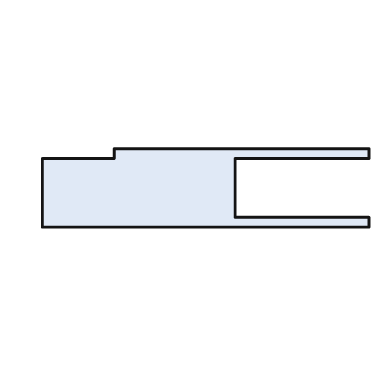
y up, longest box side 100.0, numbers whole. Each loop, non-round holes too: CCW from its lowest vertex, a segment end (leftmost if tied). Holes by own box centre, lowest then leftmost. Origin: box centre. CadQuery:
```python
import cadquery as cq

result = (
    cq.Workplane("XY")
    .moveTo(-50.0, -12.0)
    .lineTo(50.0, -12.0)
    .lineTo(50.0, -9.0)
    .lineTo(9.0, -9.0)
    .lineTo(9.0, 9.0)
    .lineTo(50.0, 9.0)
    .lineTo(50.0, 12.0)
    .lineTo(-28.0, 12.0)
    .lineTo(-28.0, 9.0)
    .lineTo(-50.0, 9.0)
    .close()
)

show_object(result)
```